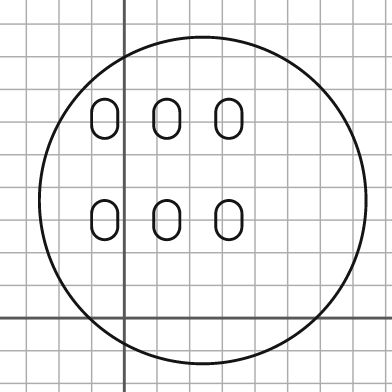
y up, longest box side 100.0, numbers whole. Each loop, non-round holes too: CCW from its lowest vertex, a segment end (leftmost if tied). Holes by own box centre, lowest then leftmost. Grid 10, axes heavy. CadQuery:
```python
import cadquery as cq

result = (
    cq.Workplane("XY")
    .moveTo(24.0, 36.0)
    .circle(50.0)
    .moveTo(-10.0, 28.0)
    .threePointArc((-6.0, 24.0), (-2.0, 28.0))
    .lineTo(-2.0, 32.0)
    .threePointArc((-6.0, 36.0), (-10.0, 32.0))
    .close()
    .moveTo(9.0, 28.0)
    .threePointArc((13.0, 24.0), (17.0, 28.0))
    .lineTo(17.0, 32.0)
    .threePointArc((13.0, 36.0), (9.0, 32.0))
    .close()
    .moveTo(28.0, 28.0)
    .threePointArc((32.0, 24.0), (36.0, 28.0))
    .lineTo(36.0, 32.0)
    .threePointArc((32.0, 36.0), (28.0, 32.0))
    .close()
    .moveTo(-10.0, 59.0)
    .threePointArc((-6.0, 55.0), (-2.0, 59.0))
    .lineTo(-2.0, 63.0)
    .threePointArc((-6.0, 67.0), (-10.0, 63.0))
    .close()
    .moveTo(9.0, 59.0)
    .threePointArc((13.0, 55.0), (17.0, 59.0))
    .lineTo(17.0, 63.0)
    .threePointArc((13.0, 67.0), (9.0, 63.0))
    .close()
    .moveTo(28.0, 59.0)
    .threePointArc((32.0, 55.0), (36.0, 59.0))
    .lineTo(36.0, 63.0)
    .threePointArc((32.0, 67.0), (28.0, 63.0))
    .close()
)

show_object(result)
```